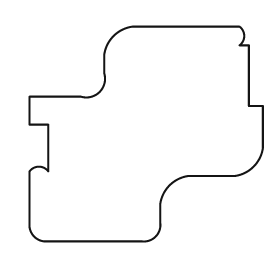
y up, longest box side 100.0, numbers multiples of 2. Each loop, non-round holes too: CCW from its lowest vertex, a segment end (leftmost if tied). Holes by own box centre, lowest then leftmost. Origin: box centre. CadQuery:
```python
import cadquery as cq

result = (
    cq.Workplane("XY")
    .moveTo(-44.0, -46.0)
    .lineTo(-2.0, -46.0)
    .threePointArc((4.0, -44.0), (6.0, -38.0))
    .lineTo(6.0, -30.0)
    .threePointArc((10.0, -22.0), (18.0, -18.0))
    .lineTo(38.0, -18.0)
    .threePointArc((46.0, -14.0), (50.0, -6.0))
    .lineTo(50.0, 12.0)
    .lineTo(44.0, 12.0)
    .lineTo(44.0, 38.0)
    .lineTo(40.0, 38.0)
    .threePointArc((42.0, 42.0), (40.0, 46.0))
    .lineTo(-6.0, 46.0)
    .threePointArc((-14.0, 42.0), (-18.0, 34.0))
    .lineTo(-18.0, 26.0)
    .threePointArc((-20.0, 18.0), (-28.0, 16.0))
    .lineTo(-50.0, 16.0)
    .lineTo(-50.0, 4.0)
    .lineTo(-42.0, 4.0)
    .lineTo(-42.0, -16.0)
    .threePointArc((-46.0, -14.0), (-50.0, -16.0))
    .lineTo(-50.0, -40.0)
    .threePointArc((-48.0, -44.0), (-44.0, -46.0))
    .close()
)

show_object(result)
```